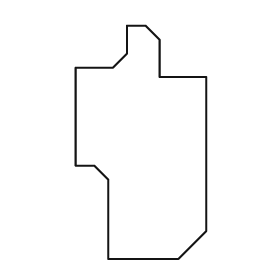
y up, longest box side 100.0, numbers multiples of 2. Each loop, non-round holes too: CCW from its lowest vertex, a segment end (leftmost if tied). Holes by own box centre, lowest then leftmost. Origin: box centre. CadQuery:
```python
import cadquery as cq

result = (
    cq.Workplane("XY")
    .moveTo(-14.0, -50.0)
    .lineTo(16.0, -50.0)
    .lineTo(28.0, -38.0)
    .lineTo(28.0, 28.0)
    .lineTo(8.0, 28.0)
    .lineTo(8.0, 44.0)
    .lineTo(2.0, 50.0)
    .lineTo(-6.0, 50.0)
    .lineTo(-6.0, 38.0)
    .lineTo(-12.0, 32.0)
    .lineTo(-28.0, 32.0)
    .lineTo(-28.0, -10.0)
    .lineTo(-20.0, -10.0)
    .lineTo(-14.0, -16.0)
    .close()
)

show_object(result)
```